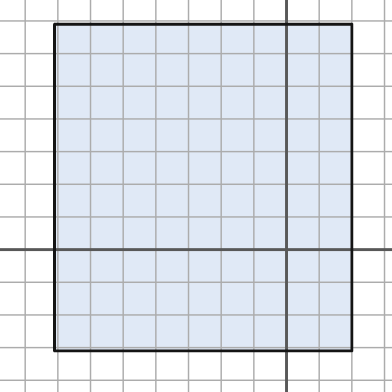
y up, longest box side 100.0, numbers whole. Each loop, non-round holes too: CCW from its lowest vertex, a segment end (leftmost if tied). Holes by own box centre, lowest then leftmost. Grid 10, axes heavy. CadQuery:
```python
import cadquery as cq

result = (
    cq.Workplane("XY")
    .moveTo(-71.0, -31.0)
    .lineTo(20.0, -31.0)
    .lineTo(20.0, 69.0)
    .lineTo(-71.0, 69.0)
    .close()
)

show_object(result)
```